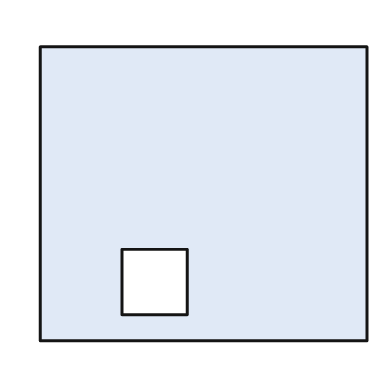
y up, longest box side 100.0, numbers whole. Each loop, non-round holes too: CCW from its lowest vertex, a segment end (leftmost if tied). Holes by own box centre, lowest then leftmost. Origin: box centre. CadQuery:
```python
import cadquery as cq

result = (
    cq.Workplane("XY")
    .moveTo(-50.0, -45.0)
    .lineTo(50.0, -45.0)
    .lineTo(50.0, 45.0)
    .lineTo(-50.0, 45.0)
    .close()
    .moveTo(-25.0, -37.0)
    .lineTo(-5.0, -37.0)
    .lineTo(-5.0, -17.0)
    .lineTo(-25.0, -17.0)
    .close()
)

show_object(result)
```